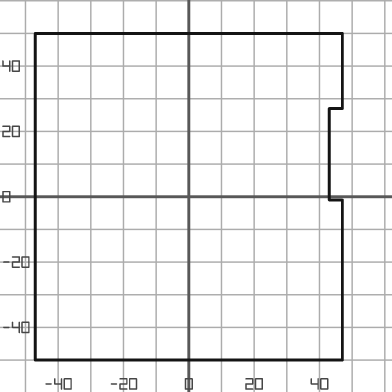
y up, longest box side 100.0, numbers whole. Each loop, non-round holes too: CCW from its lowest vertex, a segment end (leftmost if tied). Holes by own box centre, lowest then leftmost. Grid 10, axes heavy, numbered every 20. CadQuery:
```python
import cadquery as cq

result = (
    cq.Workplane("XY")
    .moveTo(-47.0, -50.0)
    .lineTo(47.0, -50.0)
    .lineTo(47.0, -1.0)
    .lineTo(43.0, -1.0)
    .lineTo(43.0, 27.0)
    .lineTo(47.0, 27.0)
    .lineTo(47.0, 50.0)
    .lineTo(-47.0, 50.0)
    .close()
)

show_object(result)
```